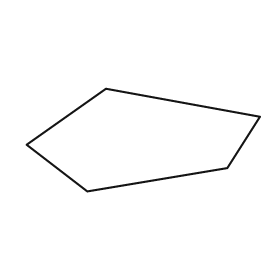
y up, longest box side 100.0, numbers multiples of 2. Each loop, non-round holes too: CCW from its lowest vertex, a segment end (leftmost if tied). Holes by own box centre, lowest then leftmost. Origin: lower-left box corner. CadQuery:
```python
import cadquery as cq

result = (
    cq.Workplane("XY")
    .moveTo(26.0, 0.0)
    .lineTo(86.0, 10.0)
    .lineTo(100.0, 32.0)
    .lineTo(34.0, 44.0)
    .lineTo(0.0, 20.0)
    .close()
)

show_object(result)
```